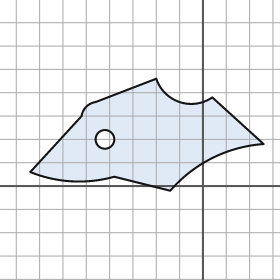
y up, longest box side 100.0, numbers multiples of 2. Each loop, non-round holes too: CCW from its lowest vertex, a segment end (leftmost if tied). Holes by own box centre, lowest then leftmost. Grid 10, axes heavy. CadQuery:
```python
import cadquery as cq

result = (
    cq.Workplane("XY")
    .moveTo(-14.0, -2.0)
    .threePointArc((4.0, 12.0), (26.0, 18.0))
    .lineTo(4.0, 38.0)
    .threePointArc((-10.0, 36.0), (-20.0, 46.0))
    .lineTo(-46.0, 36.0)
    .threePointArc((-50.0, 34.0), (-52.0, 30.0))
    .lineTo(-74.0, 6.0)
    .threePointArc((-56.0, 2.0), (-38.0, 4.0))
    .close()
    .moveTo(-42.0, 20.0)
    .circle(4.0)
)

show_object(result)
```